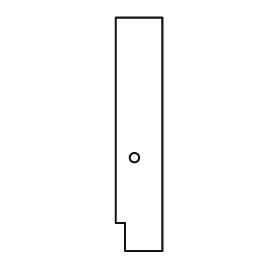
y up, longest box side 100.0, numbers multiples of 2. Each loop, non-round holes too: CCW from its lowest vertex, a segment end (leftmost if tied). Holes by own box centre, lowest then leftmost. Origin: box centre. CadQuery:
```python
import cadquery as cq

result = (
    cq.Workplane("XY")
    .moveTo(-6.0, -50.0)
    .lineTo(10.0, -50.0)
    .lineTo(10.0, 50.0)
    .lineTo(-10.0, 50.0)
    .lineTo(-10.0, -38.0)
    .lineTo(-6.0, -38.0)
    .close()
    .moveTo(-2.0, -10.0)
    .circle(2.0)
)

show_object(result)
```